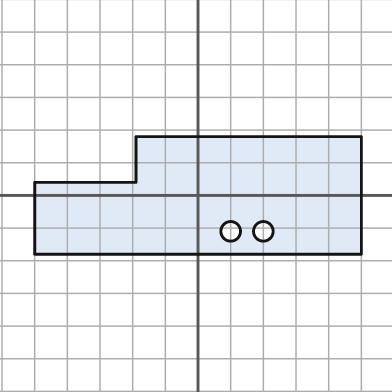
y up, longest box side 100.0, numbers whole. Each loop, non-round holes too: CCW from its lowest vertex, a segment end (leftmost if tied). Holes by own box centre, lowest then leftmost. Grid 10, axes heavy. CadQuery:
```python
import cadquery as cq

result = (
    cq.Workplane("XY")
    .moveTo(-50.0, -18.0)
    .lineTo(50.0, -18.0)
    .lineTo(50.0, 18.0)
    .lineTo(-19.0, 18.0)
    .lineTo(-19.0, 4.0)
    .lineTo(-50.0, 4.0)
    .close()
    .moveTo(10.0, -11.0)
    .circle(3.0)
    .moveTo(20.0, -11.0)
    .circle(3.0)
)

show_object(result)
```